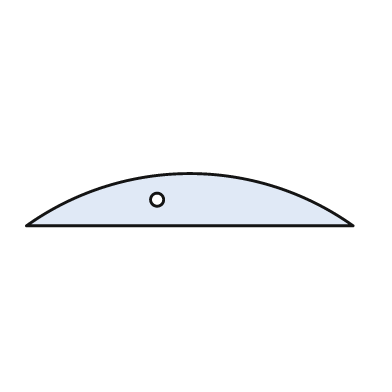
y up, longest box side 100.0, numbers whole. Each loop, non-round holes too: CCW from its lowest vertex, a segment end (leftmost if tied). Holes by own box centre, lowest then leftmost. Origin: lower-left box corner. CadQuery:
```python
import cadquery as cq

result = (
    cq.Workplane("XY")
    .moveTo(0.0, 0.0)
    .lineTo(100.0, 0.0)
    .threePointArc((50.0, 16.0), (0.0, 0.0))
    .close()
    .moveTo(40.0, 8.0)
    .circle(2.0)
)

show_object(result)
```